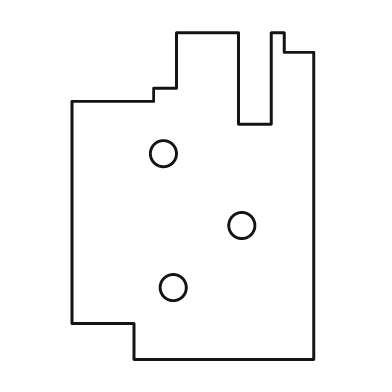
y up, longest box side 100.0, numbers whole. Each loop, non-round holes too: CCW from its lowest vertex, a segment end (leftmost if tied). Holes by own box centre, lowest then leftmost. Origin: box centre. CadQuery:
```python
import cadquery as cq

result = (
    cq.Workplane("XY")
    .moveTo(-18.0, -50.0)
    .lineTo(37.0, -50.0)
    .lineTo(37.0, 44.0)
    .lineTo(28.0, 44.0)
    .lineTo(28.0, 50.0)
    .lineTo(24.0, 50.0)
    .lineTo(24.0, 22.0)
    .lineTo(14.0, 22.0)
    .lineTo(14.0, 50.0)
    .lineTo(-5.0, 50.0)
    .lineTo(-5.0, 33.0)
    .lineTo(-12.0, 33.0)
    .lineTo(-12.0, 29.0)
    .lineTo(-37.0, 29.0)
    .lineTo(-37.0, -39.0)
    .lineTo(-18.0, -39.0)
    .close()
    .moveTo(-6.0, -28.0)
    .circle(4.0)
    .moveTo(15.0, -9.0)
    .circle(4.0)
    .moveTo(-9.0, 13.0)
    .circle(4.0)
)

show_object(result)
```